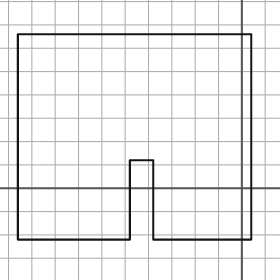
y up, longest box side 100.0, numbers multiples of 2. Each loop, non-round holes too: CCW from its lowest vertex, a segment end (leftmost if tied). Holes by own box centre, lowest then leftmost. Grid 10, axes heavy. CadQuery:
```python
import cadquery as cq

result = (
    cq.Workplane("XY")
    .moveTo(-96.0, -22.0)
    .lineTo(-48.0, -22.0)
    .lineTo(-48.0, 12.0)
    .lineTo(-38.0, 12.0)
    .lineTo(-38.0, -22.0)
    .lineTo(4.0, -22.0)
    .lineTo(4.0, 66.0)
    .lineTo(-96.0, 66.0)
    .close()
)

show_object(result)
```